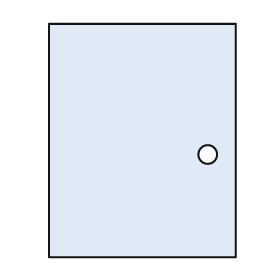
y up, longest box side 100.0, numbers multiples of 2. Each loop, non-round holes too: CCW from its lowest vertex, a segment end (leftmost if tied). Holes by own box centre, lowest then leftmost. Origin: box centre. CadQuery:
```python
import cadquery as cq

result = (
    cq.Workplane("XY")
    .moveTo(-40.0, -50.0)
    .lineTo(40.0, -50.0)
    .lineTo(40.0, 50.0)
    .lineTo(-40.0, 50.0)
    .close()
    .moveTo(28.0, -6.0)
    .circle(4.0)
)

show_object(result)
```